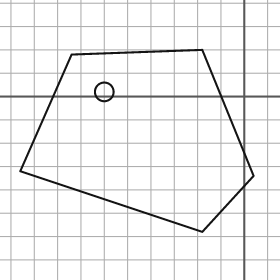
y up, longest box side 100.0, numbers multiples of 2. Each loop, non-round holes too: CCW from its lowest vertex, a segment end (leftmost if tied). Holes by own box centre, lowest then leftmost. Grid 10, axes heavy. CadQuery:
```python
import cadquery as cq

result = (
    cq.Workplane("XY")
    .moveTo(-18.0, -58.0)
    .lineTo(4.0, -34.0)
    .lineTo(-18.0, 20.0)
    .lineTo(-74.0, 18.0)
    .lineTo(-96.0, -32.0)
    .close()
    .moveTo(-60.0, 2.0)
    .circle(4.0)
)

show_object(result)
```